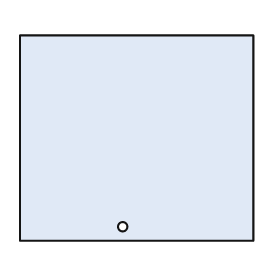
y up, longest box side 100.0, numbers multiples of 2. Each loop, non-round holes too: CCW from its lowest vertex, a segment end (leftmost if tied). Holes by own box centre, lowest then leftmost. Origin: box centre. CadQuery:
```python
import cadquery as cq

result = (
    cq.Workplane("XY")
    .moveTo(-50.0, -44.0)
    .lineTo(50.0, -44.0)
    .lineTo(50.0, 44.0)
    .lineTo(-50.0, 44.0)
    .close()
    .moveTo(-6.0, -38.0)
    .circle(2.0)
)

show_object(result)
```